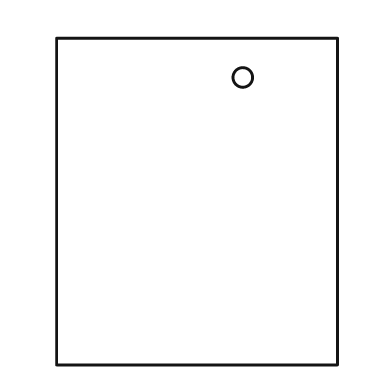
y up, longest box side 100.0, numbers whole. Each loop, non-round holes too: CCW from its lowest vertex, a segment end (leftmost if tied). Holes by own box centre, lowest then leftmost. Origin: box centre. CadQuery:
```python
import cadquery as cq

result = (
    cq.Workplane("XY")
    .moveTo(-43.0, -50.0)
    .lineTo(43.0, -50.0)
    .lineTo(43.0, 50.0)
    .lineTo(-43.0, 50.0)
    .close()
    .moveTo(14.0, 38.0)
    .circle(3.0)
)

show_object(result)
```